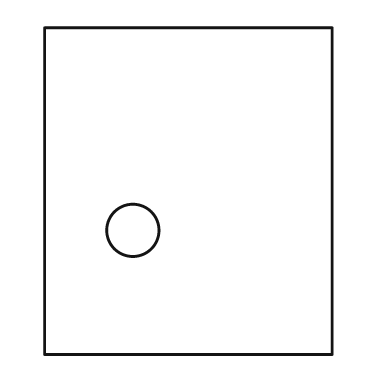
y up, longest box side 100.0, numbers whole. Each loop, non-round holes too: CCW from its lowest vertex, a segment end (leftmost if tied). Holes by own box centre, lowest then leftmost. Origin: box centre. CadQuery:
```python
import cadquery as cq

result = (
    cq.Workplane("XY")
    .moveTo(-44.0, -50.0)
    .lineTo(44.0, -50.0)
    .lineTo(44.0, 50.0)
    .lineTo(-44.0, 50.0)
    .close()
    .moveTo(-17.0, -12.0)
    .circle(8.0)
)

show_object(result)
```